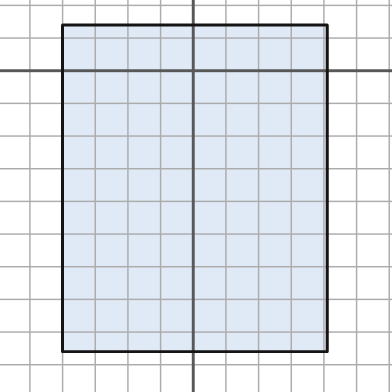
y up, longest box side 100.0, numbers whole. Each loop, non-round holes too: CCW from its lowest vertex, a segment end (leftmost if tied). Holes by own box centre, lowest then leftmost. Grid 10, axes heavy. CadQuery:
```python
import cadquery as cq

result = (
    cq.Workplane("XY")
    .moveTo(-40.0, -86.0)
    .lineTo(41.0, -86.0)
    .lineTo(41.0, 14.0)
    .lineTo(-40.0, 14.0)
    .close()
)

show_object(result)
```